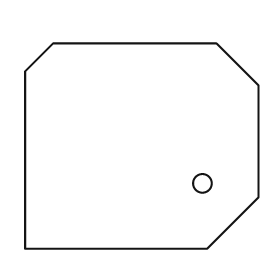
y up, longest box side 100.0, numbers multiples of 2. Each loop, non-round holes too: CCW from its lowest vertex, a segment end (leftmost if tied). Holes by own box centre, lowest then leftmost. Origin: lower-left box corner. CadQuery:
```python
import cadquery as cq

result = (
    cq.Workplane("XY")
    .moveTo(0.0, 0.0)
    .lineTo(78.0, 0.0)
    .lineTo(100.0, 22.0)
    .lineTo(100.0, 70.0)
    .lineTo(82.0, 88.0)
    .lineTo(12.0, 88.0)
    .lineTo(0.0, 76.0)
    .close()
    .moveTo(76.0, 28.0)
    .circle(4.0)
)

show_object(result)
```